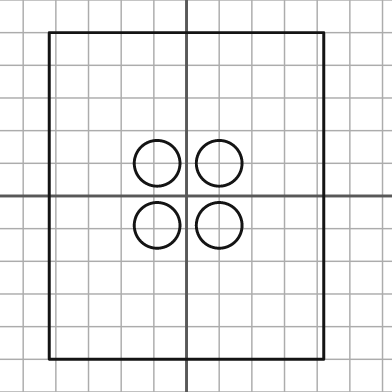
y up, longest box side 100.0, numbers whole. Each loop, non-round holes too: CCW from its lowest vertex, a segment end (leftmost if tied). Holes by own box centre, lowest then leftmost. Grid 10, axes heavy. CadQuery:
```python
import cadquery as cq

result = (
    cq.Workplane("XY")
    .moveTo(-42.0, -50.0)
    .lineTo(42.0, -50.0)
    .lineTo(42.0, 50.0)
    .lineTo(-42.0, 50.0)
    .close()
    .moveTo(-9.0, -9.0)
    .circle(7.0)
    .moveTo(10.0, -9.0)
    .circle(7.0)
    .moveTo(-9.0, 10.0)
    .circle(7.0)
    .moveTo(10.0, 10.0)
    .circle(7.0)
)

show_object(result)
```